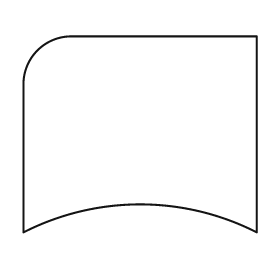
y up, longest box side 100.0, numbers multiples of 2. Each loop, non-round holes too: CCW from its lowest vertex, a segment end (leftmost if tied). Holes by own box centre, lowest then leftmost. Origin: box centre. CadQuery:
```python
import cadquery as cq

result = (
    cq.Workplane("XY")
    .moveTo(-50.0, -42.0)
    .threePointArc((0.0, -30.0), (50.0, -42.0))
    .lineTo(50.0, 42.0)
    .lineTo(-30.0, 42.0)
    .threePointArc((-44.0, 36.0), (-50.0, 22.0))
    .close()
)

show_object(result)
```